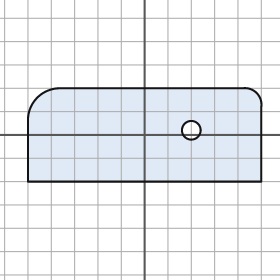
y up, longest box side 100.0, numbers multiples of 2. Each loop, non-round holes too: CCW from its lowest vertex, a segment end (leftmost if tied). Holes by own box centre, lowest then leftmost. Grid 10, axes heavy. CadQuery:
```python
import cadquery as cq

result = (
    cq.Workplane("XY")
    .moveTo(-50.0, -20.0)
    .lineTo(50.0, -20.0)
    .lineTo(50.0, 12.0)
    .threePointArc((48.0, 18.0), (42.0, 20.0))
    .lineTo(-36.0, 20.0)
    .threePointArc((-46.0, 16.0), (-50.0, 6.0))
    .close()
    .moveTo(20.0, 2.0)
    .circle(4.0)
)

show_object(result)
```